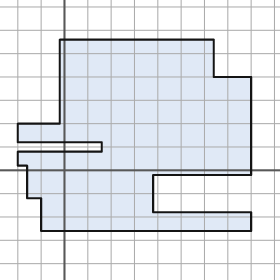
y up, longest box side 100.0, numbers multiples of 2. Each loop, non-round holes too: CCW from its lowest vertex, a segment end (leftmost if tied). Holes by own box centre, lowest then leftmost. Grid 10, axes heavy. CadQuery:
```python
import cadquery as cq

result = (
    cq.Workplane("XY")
    .moveTo(-10.0, -26.0)
    .lineTo(80.0, -26.0)
    .lineTo(80.0, -18.0)
    .lineTo(38.0, -18.0)
    .lineTo(38.0, -2.0)
    .lineTo(80.0, -2.0)
    .lineTo(80.0, 40.0)
    .lineTo(64.0, 40.0)
    .lineTo(64.0, 56.0)
    .lineTo(-2.0, 56.0)
    .lineTo(-2.0, 20.0)
    .lineTo(-20.0, 20.0)
    .lineTo(-20.0, 12.0)
    .lineTo(16.0, 12.0)
    .lineTo(16.0, 8.0)
    .lineTo(-20.0, 8.0)
    .lineTo(-20.0, 2.0)
    .lineTo(-16.0, 2.0)
    .lineTo(-16.0, -12.0)
    .lineTo(-10.0, -12.0)
    .close()
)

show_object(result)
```